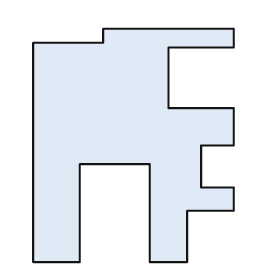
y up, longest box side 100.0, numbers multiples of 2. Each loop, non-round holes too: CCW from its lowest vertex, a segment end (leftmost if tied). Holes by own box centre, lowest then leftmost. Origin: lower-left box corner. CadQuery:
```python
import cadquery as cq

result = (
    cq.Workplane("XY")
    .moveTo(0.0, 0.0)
    .lineTo(20.0, 0.0)
    .lineTo(20.0, 42.0)
    .lineTo(50.0, 42.0)
    .lineTo(50.0, 0.0)
    .lineTo(66.0, 0.0)
    .lineTo(66.0, 22.0)
    .lineTo(86.0, 22.0)
    .lineTo(86.0, 32.0)
    .lineTo(72.0, 32.0)
    .lineTo(72.0, 50.0)
    .lineTo(86.0, 50.0)
    .lineTo(86.0, 66.0)
    .lineTo(58.0, 66.0)
    .lineTo(58.0, 92.0)
    .lineTo(86.0, 92.0)
    .lineTo(86.0, 100.0)
    .lineTo(30.0, 100.0)
    .lineTo(30.0, 94.0)
    .lineTo(0.0, 94.0)
    .close()
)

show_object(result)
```